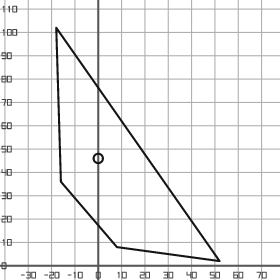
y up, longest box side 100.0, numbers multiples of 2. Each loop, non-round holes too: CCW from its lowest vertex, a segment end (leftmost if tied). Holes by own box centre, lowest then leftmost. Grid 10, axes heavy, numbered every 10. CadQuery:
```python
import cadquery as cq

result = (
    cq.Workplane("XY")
    .moveTo(52.0, 2.0)
    .lineTo(-18.0, 102.0)
    .lineTo(-16.0, 36.0)
    .lineTo(8.0, 8.0)
    .close()
    .moveTo(0.0, 46.0)
    .circle(2.0)
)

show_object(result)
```